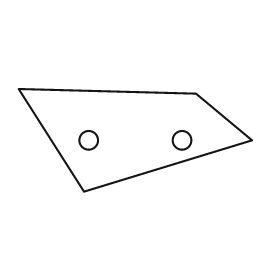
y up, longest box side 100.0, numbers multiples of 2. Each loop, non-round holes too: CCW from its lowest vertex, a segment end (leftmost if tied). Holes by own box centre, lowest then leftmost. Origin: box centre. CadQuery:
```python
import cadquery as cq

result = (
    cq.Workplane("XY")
    .moveTo(-22.0, -22.0)
    .lineTo(50.0, 0.0)
    .lineTo(26.0, 20.0)
    .lineTo(-50.0, 22.0)
    .close()
    .moveTo(-20.0, 0.0)
    .circle(4.0)
    .moveTo(20.0, 0.0)
    .circle(4.0)
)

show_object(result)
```